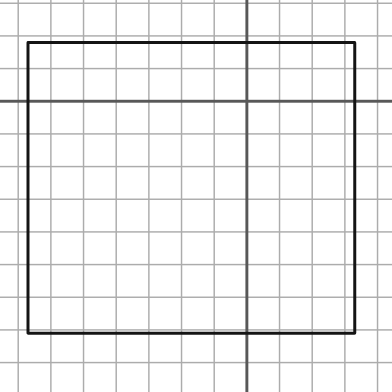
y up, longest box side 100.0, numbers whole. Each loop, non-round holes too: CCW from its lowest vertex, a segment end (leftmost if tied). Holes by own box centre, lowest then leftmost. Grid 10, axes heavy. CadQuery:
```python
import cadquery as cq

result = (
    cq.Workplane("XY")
    .moveTo(-67.0, -71.0)
    .lineTo(33.0, -71.0)
    .lineTo(33.0, 18.0)
    .lineTo(-67.0, 18.0)
    .close()
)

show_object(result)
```